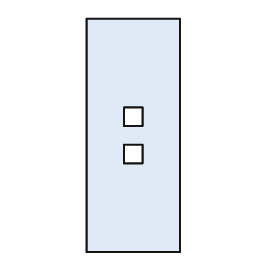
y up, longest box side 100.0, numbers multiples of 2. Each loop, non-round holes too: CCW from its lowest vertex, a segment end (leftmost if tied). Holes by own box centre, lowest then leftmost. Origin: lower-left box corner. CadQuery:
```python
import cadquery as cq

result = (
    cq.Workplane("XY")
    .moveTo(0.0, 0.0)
    .lineTo(40.0, 0.0)
    .lineTo(40.0, 100.0)
    .lineTo(0.0, 100.0)
    .close()
    .moveTo(16.0, 38.0)
    .lineTo(24.0, 38.0)
    .lineTo(24.0, 46.0)
    .lineTo(16.0, 46.0)
    .close()
    .moveTo(16.0, 54.0)
    .lineTo(24.0, 54.0)
    .lineTo(24.0, 62.0)
    .lineTo(16.0, 62.0)
    .close()
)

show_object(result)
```